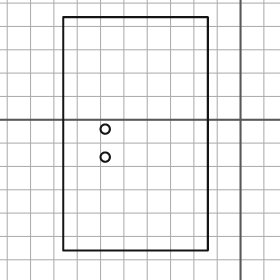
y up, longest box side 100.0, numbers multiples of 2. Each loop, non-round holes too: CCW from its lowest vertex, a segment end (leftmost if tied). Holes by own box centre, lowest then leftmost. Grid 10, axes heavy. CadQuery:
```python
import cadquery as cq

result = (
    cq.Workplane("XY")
    .moveTo(-76.0, -56.0)
    .lineTo(-14.0, -56.0)
    .lineTo(-14.0, 44.0)
    .lineTo(-76.0, 44.0)
    .close()
    .moveTo(-58.0, -16.0)
    .circle(2.0)
    .moveTo(-58.0, -4.0)
    .circle(2.0)
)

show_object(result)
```